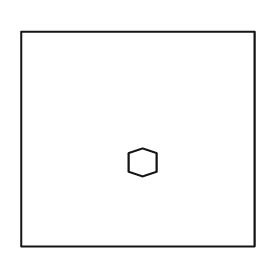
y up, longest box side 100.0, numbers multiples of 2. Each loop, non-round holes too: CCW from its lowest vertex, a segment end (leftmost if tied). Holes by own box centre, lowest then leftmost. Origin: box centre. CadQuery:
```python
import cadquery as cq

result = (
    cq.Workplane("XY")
    .moveTo(-50.0, -46.0)
    .lineTo(50.0, -46.0)
    .lineTo(50.0, 46.0)
    .lineTo(-50.0, 46.0)
    .close()
    .moveTo(2.0, -16.0)
    .lineTo(8.0, -14.0)
    .lineTo(8.0, -6.0)
    .lineTo(2.0, -4.0)
    .lineTo(-4.0, -6.0)
    .lineTo(-4.0, -14.0)
    .close()
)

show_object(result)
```